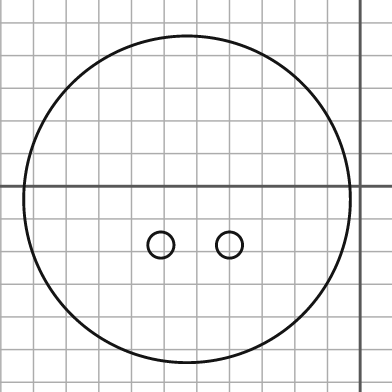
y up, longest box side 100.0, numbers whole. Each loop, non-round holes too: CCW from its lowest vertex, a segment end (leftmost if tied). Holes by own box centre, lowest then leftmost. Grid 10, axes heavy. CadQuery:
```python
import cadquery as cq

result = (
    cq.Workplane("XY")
    .moveTo(-53.0, -4.0)
    .circle(50.0)
    .moveTo(-61.0, -18.0)
    .circle(4.0)
    .moveTo(-40.0, -18.0)
    .circle(4.0)
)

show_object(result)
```